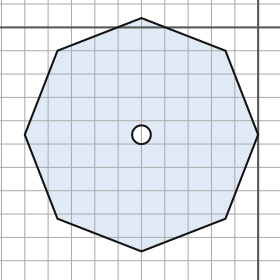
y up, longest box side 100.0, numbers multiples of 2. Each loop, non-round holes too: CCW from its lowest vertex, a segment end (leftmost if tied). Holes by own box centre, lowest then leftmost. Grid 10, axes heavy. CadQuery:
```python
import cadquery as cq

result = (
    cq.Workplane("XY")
    .moveTo(-50.0, -96.0)
    .lineTo(-14.0, -82.0)
    .lineTo(0.0, -46.0)
    .lineTo(-14.0, -10.0)
    .lineTo(-50.0, 4.0)
    .lineTo(-86.0, -10.0)
    .lineTo(-100.0, -46.0)
    .lineTo(-86.0, -82.0)
    .close()
    .moveTo(-50.0, -46.0)
    .circle(4.0)
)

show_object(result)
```